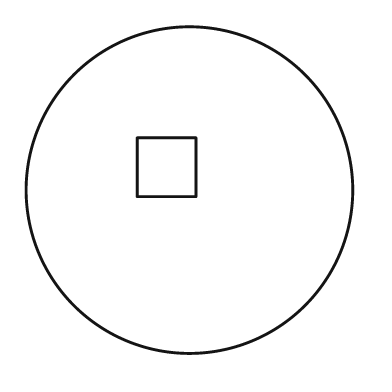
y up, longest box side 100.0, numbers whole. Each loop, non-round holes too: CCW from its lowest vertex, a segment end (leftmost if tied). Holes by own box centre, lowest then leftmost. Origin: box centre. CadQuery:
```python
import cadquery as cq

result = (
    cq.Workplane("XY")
    .moveTo(0.0, 0.0)
    .circle(50.0)
    .moveTo(-16.0, -2.0)
    .lineTo(2.0, -2.0)
    .lineTo(2.0, 16.0)
    .lineTo(-16.0, 16.0)
    .close()
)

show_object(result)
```